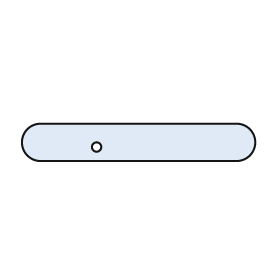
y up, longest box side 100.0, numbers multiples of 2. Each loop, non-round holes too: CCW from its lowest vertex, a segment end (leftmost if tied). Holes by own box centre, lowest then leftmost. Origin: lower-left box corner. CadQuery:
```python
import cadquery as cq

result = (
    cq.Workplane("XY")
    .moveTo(8.0, 0.0)
    .lineTo(92.0, 0.0)
    .threePointArc((100.0, 8.0), (92.0, 16.0))
    .lineTo(8.0, 16.0)
    .threePointArc((0.0, 8.0), (8.0, 0.0))
    .close()
    .moveTo(32.0, 6.0)
    .circle(2.0)
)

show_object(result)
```